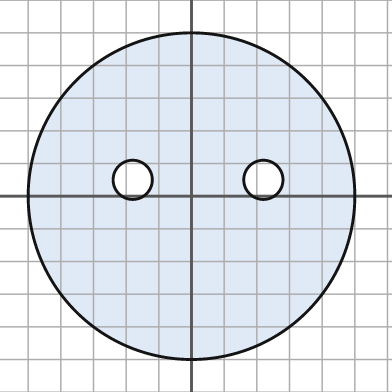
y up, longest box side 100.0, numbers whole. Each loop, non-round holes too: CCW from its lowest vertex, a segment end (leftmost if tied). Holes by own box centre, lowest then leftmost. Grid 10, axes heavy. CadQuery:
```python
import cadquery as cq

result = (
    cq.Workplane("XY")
    .moveTo(0.0, 0.0)
    .circle(50.0)
    .moveTo(-18.0, 5.0)
    .circle(6.0)
    .moveTo(22.0, 5.0)
    .circle(6.0)
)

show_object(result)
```